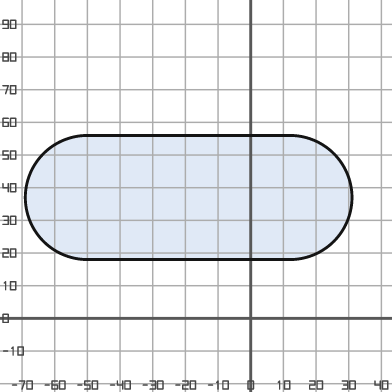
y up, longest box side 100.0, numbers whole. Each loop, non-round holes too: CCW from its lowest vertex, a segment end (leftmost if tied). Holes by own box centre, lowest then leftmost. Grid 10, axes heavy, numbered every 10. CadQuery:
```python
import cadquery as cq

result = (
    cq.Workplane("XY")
    .moveTo(-50.0, 18.0)
    .lineTo(12.0, 18.0)
    .threePointArc((31.0, 37.0), (12.0, 56.0))
    .lineTo(-50.0, 56.0)
    .threePointArc((-69.0, 37.0), (-50.0, 18.0))
    .close()
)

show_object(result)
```